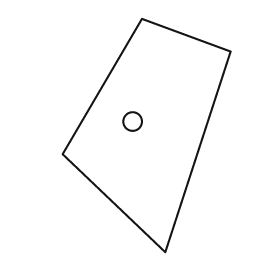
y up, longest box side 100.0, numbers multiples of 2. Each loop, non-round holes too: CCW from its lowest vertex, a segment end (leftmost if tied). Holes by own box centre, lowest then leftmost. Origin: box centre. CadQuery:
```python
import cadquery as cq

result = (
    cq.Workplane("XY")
    .moveTo(8.0, -50.0)
    .lineTo(36.0, 36.0)
    .lineTo(-2.0, 50.0)
    .lineTo(-36.0, -8.0)
    .close()
    .moveTo(-6.0, 6.0)
    .circle(4.0)
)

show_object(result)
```